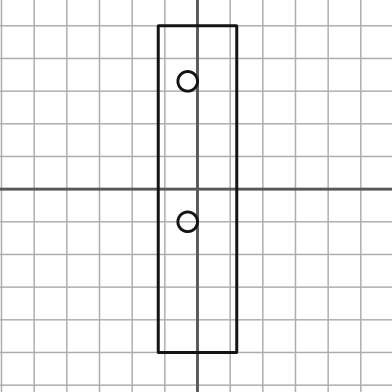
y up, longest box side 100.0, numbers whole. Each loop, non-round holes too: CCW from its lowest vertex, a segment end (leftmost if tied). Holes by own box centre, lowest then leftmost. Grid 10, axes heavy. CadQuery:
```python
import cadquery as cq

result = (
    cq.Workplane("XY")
    .moveTo(-12.0, -50.0)
    .lineTo(12.0, -50.0)
    .lineTo(12.0, 50.0)
    .lineTo(-12.0, 50.0)
    .close()
    .moveTo(-3.0, -10.0)
    .circle(3.0)
    .moveTo(-3.0, 33.0)
    .circle(3.0)
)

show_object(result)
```